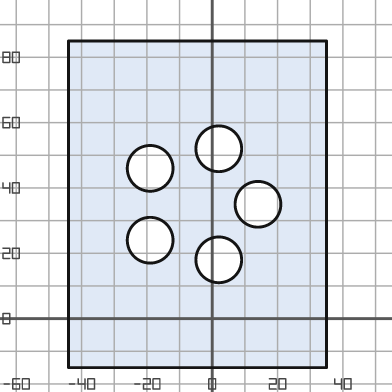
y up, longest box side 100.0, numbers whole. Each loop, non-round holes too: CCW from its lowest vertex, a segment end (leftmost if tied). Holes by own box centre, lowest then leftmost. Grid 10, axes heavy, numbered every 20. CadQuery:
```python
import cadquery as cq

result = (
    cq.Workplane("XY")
    .moveTo(-44.0, -15.0)
    .lineTo(35.0, -15.0)
    .lineTo(35.0, 85.0)
    .lineTo(-44.0, 85.0)
    .close()
    .moveTo(2.0, 18.0)
    .circle(7.0)
    .moveTo(-19.0, 24.0)
    .circle(7.0)
    .moveTo(14.0, 35.0)
    .circle(7.0)
    .moveTo(-19.0, 46.0)
    .circle(7.0)
    .moveTo(2.0, 52.0)
    .circle(7.0)
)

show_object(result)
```